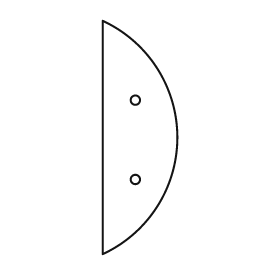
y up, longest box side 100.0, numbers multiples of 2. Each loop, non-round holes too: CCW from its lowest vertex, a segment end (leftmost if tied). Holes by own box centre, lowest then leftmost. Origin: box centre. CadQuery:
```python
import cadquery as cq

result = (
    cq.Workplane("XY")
    .moveTo(-16.0, -50.0)
    .threePointArc((16.0, 0.0), (-16.0, 50.0))
    .close()
    .moveTo(-2.0, -18.0)
    .circle(2.0)
    .moveTo(-2.0, 16.0)
    .circle(2.0)
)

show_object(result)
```